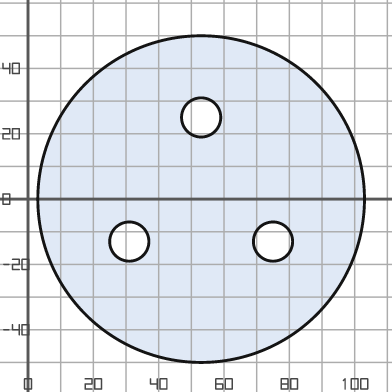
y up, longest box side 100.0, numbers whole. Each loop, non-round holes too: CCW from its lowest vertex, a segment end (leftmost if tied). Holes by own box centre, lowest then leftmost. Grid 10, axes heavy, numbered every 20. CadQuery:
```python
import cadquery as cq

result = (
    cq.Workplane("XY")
    .moveTo(53.0, 0.0)
    .circle(50.0)
    .moveTo(31.0, -13.0)
    .circle(6.0)
    .moveTo(75.0, -13.0)
    .circle(6.0)
    .moveTo(53.0, 25.0)
    .circle(6.0)
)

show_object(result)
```